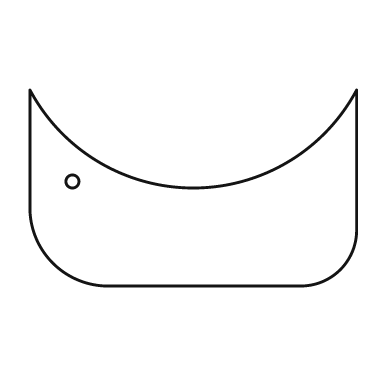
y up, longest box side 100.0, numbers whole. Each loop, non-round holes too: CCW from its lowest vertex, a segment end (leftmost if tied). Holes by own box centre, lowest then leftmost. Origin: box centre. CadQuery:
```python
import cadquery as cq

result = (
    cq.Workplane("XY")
    .moveTo(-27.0, -30.0)
    .lineTo(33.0, -30.0)
    .threePointArc((45.0, -25.0), (50.0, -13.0))
    .lineTo(50.0, 30.0)
    .threePointArc((0.0, 0.0), (-50.0, 30.0))
    .lineTo(-50.0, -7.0)
    .threePointArc((-43.0, -23.0), (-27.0, -30.0))
    .close()
    .moveTo(-37.0, 2.0)
    .circle(2.0)
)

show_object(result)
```